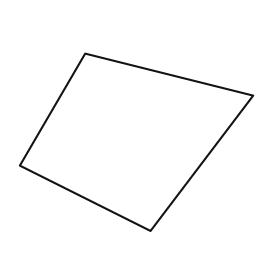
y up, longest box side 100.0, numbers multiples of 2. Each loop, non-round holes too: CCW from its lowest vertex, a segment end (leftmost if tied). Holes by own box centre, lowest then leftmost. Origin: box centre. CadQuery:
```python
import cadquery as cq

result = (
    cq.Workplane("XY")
    .moveTo(6.0, -38.0)
    .lineTo(50.0, 20.0)
    .lineTo(-22.0, 38.0)
    .lineTo(-50.0, -10.0)
    .close()
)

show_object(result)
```